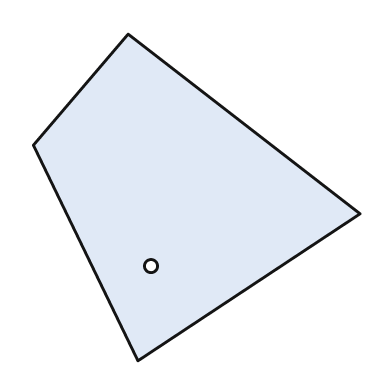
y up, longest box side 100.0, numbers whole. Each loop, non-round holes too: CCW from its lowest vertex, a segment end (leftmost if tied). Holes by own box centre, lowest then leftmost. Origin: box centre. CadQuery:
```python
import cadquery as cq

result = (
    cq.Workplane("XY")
    .moveTo(-18.0, -50.0)
    .lineTo(50.0, -5.0)
    .lineTo(-21.0, 50.0)
    .lineTo(-50.0, 16.0)
    .close()
    .moveTo(-14.0, -21.0)
    .circle(2.0)
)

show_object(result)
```